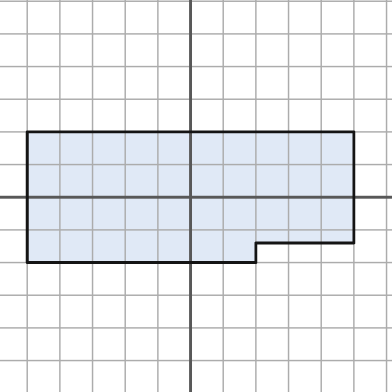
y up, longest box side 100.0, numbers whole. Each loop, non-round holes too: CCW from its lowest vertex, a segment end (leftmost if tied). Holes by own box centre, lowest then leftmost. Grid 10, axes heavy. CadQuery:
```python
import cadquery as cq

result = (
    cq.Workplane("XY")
    .moveTo(-50.0, -20.0)
    .lineTo(20.0, -20.0)
    .lineTo(20.0, -14.0)
    .lineTo(50.0, -14.0)
    .lineTo(50.0, 20.0)
    .lineTo(-50.0, 20.0)
    .close()
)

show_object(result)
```